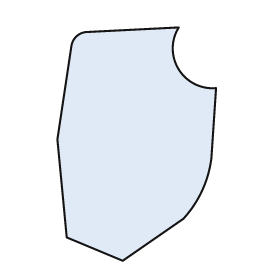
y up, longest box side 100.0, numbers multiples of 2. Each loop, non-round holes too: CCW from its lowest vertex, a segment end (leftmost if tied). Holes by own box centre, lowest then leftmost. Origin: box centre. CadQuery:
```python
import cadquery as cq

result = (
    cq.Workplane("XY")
    .moveTo(-6.0, -50.0)
    .lineTo(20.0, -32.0)
    .threePointArc((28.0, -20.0), (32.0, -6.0))
    .lineTo(34.0, 24.0)
    .threePointArc((18.0, 32.0), (18.0, 50.0))
    .lineTo(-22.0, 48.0)
    .threePointArc((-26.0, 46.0), (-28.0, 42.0))
    .lineTo(-34.0, 2.0)
    .lineTo(-30.0, -40.0)
    .close()
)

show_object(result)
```